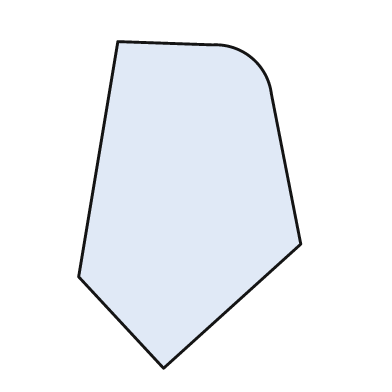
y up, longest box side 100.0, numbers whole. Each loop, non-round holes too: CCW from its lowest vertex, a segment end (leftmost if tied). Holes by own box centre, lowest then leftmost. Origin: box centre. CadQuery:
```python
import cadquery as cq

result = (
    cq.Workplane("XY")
    .moveTo(-8.0, -50.0)
    .lineTo(34.0, -12.0)
    .lineTo(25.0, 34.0)
    .threePointArc((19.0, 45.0), (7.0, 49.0))
    .lineTo(-22.0, 50.0)
    .lineTo(-34.0, -22.0)
    .close()
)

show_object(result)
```